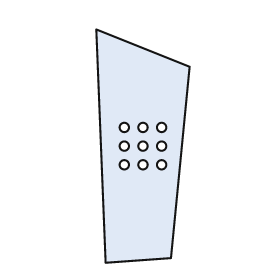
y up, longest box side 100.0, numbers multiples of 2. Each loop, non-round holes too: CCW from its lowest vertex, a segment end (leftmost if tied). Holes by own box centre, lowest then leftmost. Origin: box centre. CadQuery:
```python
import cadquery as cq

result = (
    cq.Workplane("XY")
    .moveTo(-16.0, -50.0)
    .lineTo(12.0, -48.0)
    .lineTo(20.0, 34.0)
    .lineTo(-20.0, 50.0)
    .close()
    .moveTo(-8.0, -8.0)
    .circle(2.0)
    .moveTo(0.0, -8.0)
    .circle(2.0)
    .moveTo(8.0, -8.0)
    .circle(2.0)
    .moveTo(-8.0, 0.0)
    .circle(2.0)
    .moveTo(0.0, 0.0)
    .circle(2.0)
    .moveTo(8.0, 0.0)
    .circle(2.0)
    .moveTo(-8.0, 8.0)
    .circle(2.0)
    .moveTo(0.0, 8.0)
    .circle(2.0)
    .moveTo(8.0, 8.0)
    .circle(2.0)
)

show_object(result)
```